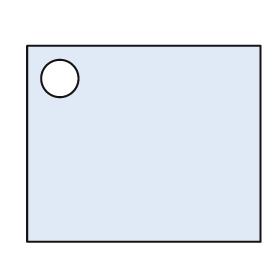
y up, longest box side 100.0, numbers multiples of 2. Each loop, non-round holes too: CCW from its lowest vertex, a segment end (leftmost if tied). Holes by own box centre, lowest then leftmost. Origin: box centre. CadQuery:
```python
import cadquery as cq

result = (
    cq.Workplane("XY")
    .moveTo(-50.0, -42.0)
    .lineTo(50.0, -42.0)
    .lineTo(50.0, 42.0)
    .lineTo(-50.0, 42.0)
    .close()
    .moveTo(-36.0, 28.0)
    .circle(8.0)
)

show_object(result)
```